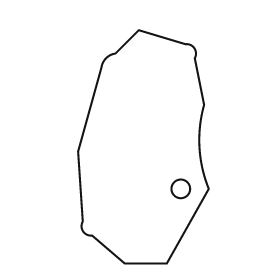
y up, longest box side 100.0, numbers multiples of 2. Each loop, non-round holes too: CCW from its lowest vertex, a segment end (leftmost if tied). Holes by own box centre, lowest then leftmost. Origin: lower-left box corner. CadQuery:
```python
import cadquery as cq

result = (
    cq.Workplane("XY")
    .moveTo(20.0, 0.0)
    .lineTo(38.0, 0.0)
    .lineTo(56.0, 32.0)
    .threePointArc((52.0, 50.0), (54.0, 68.0))
    .lineTo(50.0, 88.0)
    .threePointArc((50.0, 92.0), (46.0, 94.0))
    .lineTo(26.0, 100.0)
    .lineTo(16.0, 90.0)
    .threePointArc((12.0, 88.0), (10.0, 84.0))
    .lineTo(0.0, 48.0)
    .lineTo(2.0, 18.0)
    .threePointArc((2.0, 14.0), (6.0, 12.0))
    .close()
    .moveTo(44.0, 32.0)
    .circle(4.0)
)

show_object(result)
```